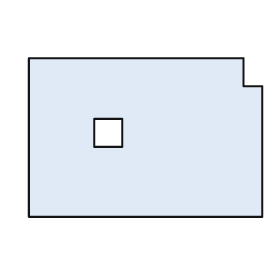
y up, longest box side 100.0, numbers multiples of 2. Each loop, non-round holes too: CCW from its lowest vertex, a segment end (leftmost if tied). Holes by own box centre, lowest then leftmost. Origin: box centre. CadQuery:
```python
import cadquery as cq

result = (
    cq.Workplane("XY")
    .moveTo(-50.0, -34.0)
    .lineTo(50.0, -34.0)
    .lineTo(50.0, 22.0)
    .lineTo(42.0, 22.0)
    .lineTo(42.0, 34.0)
    .lineTo(-50.0, 34.0)
    .close()
    .moveTo(-22.0, -4.0)
    .lineTo(-10.0, -4.0)
    .lineTo(-10.0, 8.0)
    .lineTo(-22.0, 8.0)
    .close()
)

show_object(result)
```